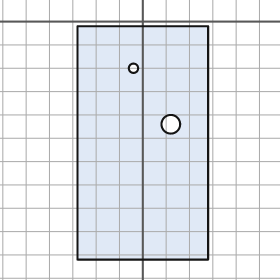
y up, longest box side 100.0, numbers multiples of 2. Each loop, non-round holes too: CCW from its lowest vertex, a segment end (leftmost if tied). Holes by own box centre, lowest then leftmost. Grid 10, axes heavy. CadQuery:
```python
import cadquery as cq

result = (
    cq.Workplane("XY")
    .moveTo(-28.0, -102.0)
    .lineTo(28.0, -102.0)
    .lineTo(28.0, -2.0)
    .lineTo(-28.0, -2.0)
    .close()
    .moveTo(12.0, -44.0)
    .circle(4.0)
    .moveTo(-4.0, -20.0)
    .circle(2.0)
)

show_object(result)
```